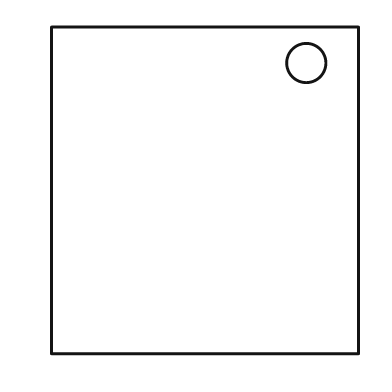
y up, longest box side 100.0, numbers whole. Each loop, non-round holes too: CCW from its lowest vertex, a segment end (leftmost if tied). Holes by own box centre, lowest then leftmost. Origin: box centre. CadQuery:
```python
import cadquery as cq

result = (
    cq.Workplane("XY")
    .moveTo(-47.0, -50.0)
    .lineTo(47.0, -50.0)
    .lineTo(47.0, 50.0)
    .lineTo(-47.0, 50.0)
    .close()
    .moveTo(31.0, 39.0)
    .circle(6.0)
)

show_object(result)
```